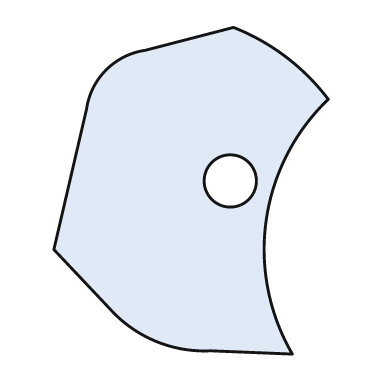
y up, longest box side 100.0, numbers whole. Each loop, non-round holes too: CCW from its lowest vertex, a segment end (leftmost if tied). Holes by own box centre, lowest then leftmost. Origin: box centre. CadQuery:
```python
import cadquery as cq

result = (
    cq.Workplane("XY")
    .moveTo(31.0, -50.0)
    .threePointArc((23.0, -9.0), (42.0, 28.0))
    .threePointArc((29.0, 41.0), (13.0, 50.0))
    .lineTo(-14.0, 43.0)
    .threePointArc((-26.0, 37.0), (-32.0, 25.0))
    .lineTo(-42.0, -18.0)
    .lineTo(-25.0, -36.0)
    .threePointArc((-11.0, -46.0), (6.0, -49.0))
    .close()
    .moveTo(12.0, 3.0)
    .circle(8.0)
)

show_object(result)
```